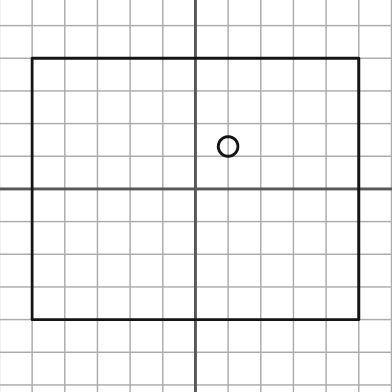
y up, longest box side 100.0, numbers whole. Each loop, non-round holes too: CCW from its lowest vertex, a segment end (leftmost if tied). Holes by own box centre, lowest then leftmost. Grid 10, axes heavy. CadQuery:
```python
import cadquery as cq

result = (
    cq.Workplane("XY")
    .moveTo(-50.0, -40.0)
    .lineTo(50.0, -40.0)
    .lineTo(50.0, 40.0)
    .lineTo(-50.0, 40.0)
    .close()
    .moveTo(10.0, 13.0)
    .circle(3.0)
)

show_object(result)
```